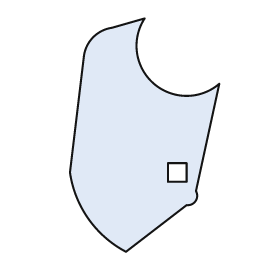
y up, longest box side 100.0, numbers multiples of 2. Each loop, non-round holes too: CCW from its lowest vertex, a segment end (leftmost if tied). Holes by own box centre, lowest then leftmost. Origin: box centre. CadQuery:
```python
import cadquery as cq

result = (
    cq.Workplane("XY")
    .moveTo(-8.0, -50.0)
    .lineTo(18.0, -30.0)
    .threePointArc((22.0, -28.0), (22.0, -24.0))
    .lineTo(32.0, 22.0)
    .threePointArc((4.0, 22.0), (0.0, 50.0))
    .lineTo(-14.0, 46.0)
    .threePointArc((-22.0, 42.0), (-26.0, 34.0))
    .lineTo(-32.0, -16.0)
    .threePointArc((-24.0, -36.0), (-8.0, -50.0))
    .close()
    .moveTo(10.0, -20.0)
    .lineTo(18.0, -20.0)
    .lineTo(18.0, -12.0)
    .lineTo(10.0, -12.0)
    .close()
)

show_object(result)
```